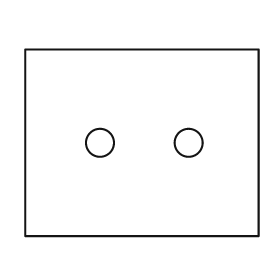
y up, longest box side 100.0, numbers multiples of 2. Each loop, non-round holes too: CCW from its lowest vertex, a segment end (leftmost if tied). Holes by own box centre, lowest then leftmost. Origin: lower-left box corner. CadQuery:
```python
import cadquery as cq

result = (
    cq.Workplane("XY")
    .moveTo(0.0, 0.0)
    .lineTo(100.0, 0.0)
    .lineTo(100.0, 80.0)
    .lineTo(0.0, 80.0)
    .close()
    .moveTo(32.0, 40.0)
    .circle(6.0)
    .moveTo(70.0, 40.0)
    .circle(6.0)
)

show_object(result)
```